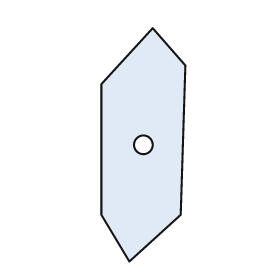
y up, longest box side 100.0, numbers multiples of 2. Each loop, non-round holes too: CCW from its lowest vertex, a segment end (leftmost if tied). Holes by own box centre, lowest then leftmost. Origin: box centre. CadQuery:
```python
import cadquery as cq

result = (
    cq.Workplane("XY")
    .moveTo(-6.0, -50.0)
    .lineTo(16.0, -30.0)
    .lineTo(18.0, 34.0)
    .lineTo(4.0, 50.0)
    .lineTo(-18.0, 26.0)
    .lineTo(-18.0, -30.0)
    .close()
    .moveTo(0.0, 0.0)
    .circle(4.0)
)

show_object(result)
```